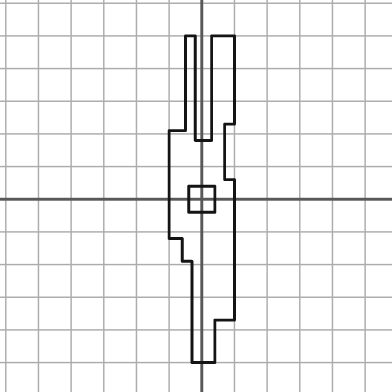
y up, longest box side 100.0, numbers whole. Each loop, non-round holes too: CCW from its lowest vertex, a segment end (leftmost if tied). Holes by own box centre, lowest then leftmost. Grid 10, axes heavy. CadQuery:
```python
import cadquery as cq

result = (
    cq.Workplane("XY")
    .moveTo(-3.0, -50.0)
    .lineTo(4.0, -50.0)
    .lineTo(4.0, -37.0)
    .lineTo(10.0, -37.0)
    .lineTo(10.0, 6.0)
    .lineTo(7.0, 6.0)
    .lineTo(7.0, 23.0)
    .lineTo(10.0, 23.0)
    .lineTo(10.0, 50.0)
    .lineTo(3.0, 50.0)
    .lineTo(3.0, 18.0)
    .lineTo(-2.0, 18.0)
    .lineTo(-2.0, 50.0)
    .lineTo(-5.0, 50.0)
    .lineTo(-5.0, 21.0)
    .lineTo(-10.0, 21.0)
    .lineTo(-10.0, -12.0)
    .lineTo(-6.0, -12.0)
    .lineTo(-6.0, -19.0)
    .lineTo(-3.0, -19.0)
    .close()
    .moveTo(-4.0, -4.0)
    .lineTo(4.0, -4.0)
    .lineTo(4.0, 4.0)
    .lineTo(-4.0, 4.0)
    .close()
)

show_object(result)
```